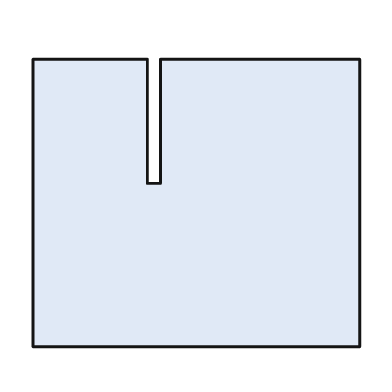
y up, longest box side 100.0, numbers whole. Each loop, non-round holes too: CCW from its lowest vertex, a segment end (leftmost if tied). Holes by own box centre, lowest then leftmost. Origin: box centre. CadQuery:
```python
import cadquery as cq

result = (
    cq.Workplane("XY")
    .moveTo(-50.0, -44.0)
    .lineTo(50.0, -44.0)
    .lineTo(50.0, 44.0)
    .lineTo(-11.0, 44.0)
    .lineTo(-11.0, 6.0)
    .lineTo(-15.0, 6.0)
    .lineTo(-15.0, 44.0)
    .lineTo(-50.0, 44.0)
    .close()
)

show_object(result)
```